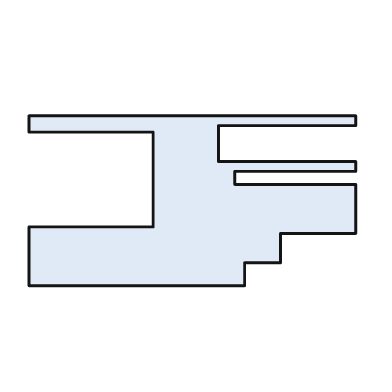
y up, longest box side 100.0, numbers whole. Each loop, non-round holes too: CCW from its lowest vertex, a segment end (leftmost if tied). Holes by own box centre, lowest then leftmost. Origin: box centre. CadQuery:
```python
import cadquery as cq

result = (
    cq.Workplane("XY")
    .moveTo(-50.0, -26.0)
    .lineTo(16.0, -26.0)
    .lineTo(16.0, -19.0)
    .lineTo(27.0, -19.0)
    .lineTo(27.0, -10.0)
    .lineTo(50.0, -10.0)
    .lineTo(50.0, 5.0)
    .lineTo(13.0, 5.0)
    .lineTo(13.0, 9.0)
    .lineTo(50.0, 9.0)
    .lineTo(50.0, 12.0)
    .lineTo(8.0, 12.0)
    .lineTo(8.0, 23.0)
    .lineTo(50.0, 23.0)
    .lineTo(50.0, 26.0)
    .lineTo(-50.0, 26.0)
    .lineTo(-50.0, 21.0)
    .lineTo(-12.0, 21.0)
    .lineTo(-12.0, -8.0)
    .lineTo(-50.0, -8.0)
    .close()
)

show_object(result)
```